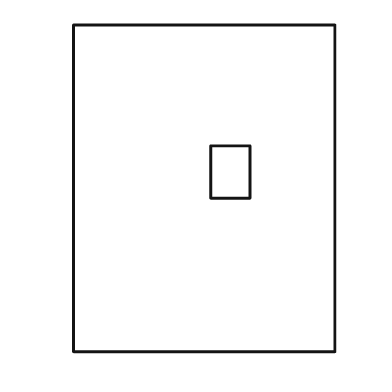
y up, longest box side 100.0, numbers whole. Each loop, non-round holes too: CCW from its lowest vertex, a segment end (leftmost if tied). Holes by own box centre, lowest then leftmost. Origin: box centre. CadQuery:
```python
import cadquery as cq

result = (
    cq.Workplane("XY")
    .moveTo(-40.0, -50.0)
    .lineTo(40.0, -50.0)
    .lineTo(40.0, 50.0)
    .lineTo(-40.0, 50.0)
    .close()
    .moveTo(2.0, -3.0)
    .lineTo(14.0, -3.0)
    .lineTo(14.0, 13.0)
    .lineTo(2.0, 13.0)
    .close()
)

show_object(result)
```